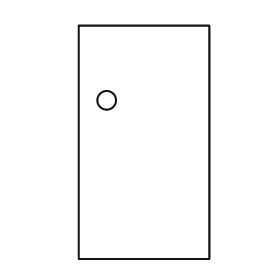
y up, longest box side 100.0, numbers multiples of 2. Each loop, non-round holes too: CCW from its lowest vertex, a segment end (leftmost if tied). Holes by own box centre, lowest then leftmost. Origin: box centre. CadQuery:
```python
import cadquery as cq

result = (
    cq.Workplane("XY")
    .moveTo(-28.0, -50.0)
    .lineTo(28.0, -50.0)
    .lineTo(28.0, 50.0)
    .lineTo(-28.0, 50.0)
    .close()
    .moveTo(-16.0, 18.0)
    .circle(4.0)
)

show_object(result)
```